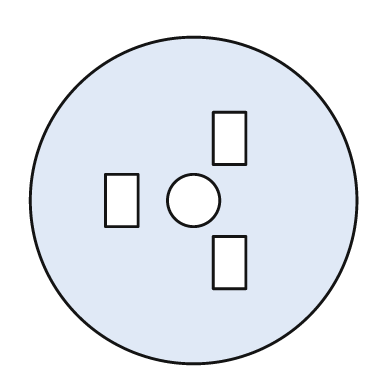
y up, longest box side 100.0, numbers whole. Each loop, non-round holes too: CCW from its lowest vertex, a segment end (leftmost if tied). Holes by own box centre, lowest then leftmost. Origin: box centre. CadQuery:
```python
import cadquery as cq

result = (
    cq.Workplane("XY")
    .moveTo(0.0, 0.0)
    .circle(50.0)
    .moveTo(6.0, -27.0)
    .lineTo(16.0, -27.0)
    .lineTo(16.0, -11.0)
    .lineTo(6.0, -11.0)
    .close()
    .moveTo(-27.0, -8.0)
    .lineTo(-17.0, -8.0)
    .lineTo(-17.0, 8.0)
    .lineTo(-27.0, 8.0)
    .close()
    .moveTo(0.0, 0.0)
    .circle(8.0)
    .moveTo(6.0, 11.0)
    .lineTo(16.0, 11.0)
    .lineTo(16.0, 27.0)
    .lineTo(6.0, 27.0)
    .close()
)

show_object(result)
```